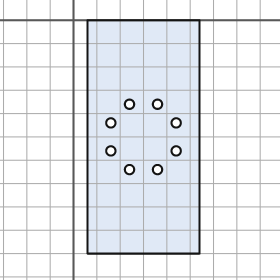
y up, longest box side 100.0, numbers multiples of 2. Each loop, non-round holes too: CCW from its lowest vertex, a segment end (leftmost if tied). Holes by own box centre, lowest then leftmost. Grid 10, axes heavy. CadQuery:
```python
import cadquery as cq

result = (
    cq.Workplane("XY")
    .moveTo(6.0, -100.0)
    .lineTo(54.0, -100.0)
    .lineTo(54.0, 0.0)
    .lineTo(6.0, 0.0)
    .close()
    .moveTo(24.0, -64.0)
    .circle(2.0)
    .moveTo(36.0, -64.0)
    .circle(2.0)
    .moveTo(16.0, -56.0)
    .circle(2.0)
    .moveTo(44.0, -56.0)
    .circle(2.0)
    .moveTo(16.0, -44.0)
    .circle(2.0)
    .moveTo(44.0, -44.0)
    .circle(2.0)
    .moveTo(24.0, -36.0)
    .circle(2.0)
    .moveTo(36.0, -36.0)
    .circle(2.0)
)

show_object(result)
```